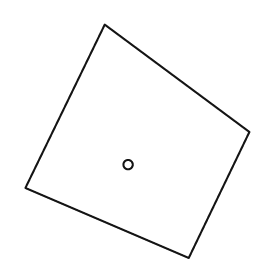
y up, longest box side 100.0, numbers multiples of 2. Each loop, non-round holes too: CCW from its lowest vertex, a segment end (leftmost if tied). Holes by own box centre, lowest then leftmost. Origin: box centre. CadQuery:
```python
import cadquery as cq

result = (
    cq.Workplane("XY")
    .moveTo(22.0, -50.0)
    .lineTo(48.0, 4.0)
    .lineTo(-14.0, 50.0)
    .lineTo(-48.0, -20.0)
    .close()
    .moveTo(-4.0, -10.0)
    .circle(2.0)
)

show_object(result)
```